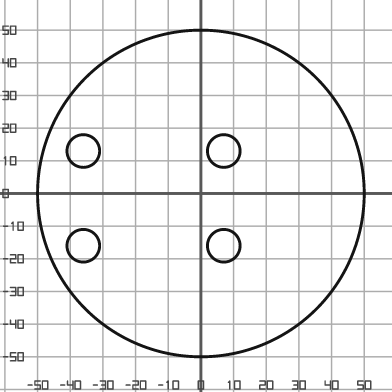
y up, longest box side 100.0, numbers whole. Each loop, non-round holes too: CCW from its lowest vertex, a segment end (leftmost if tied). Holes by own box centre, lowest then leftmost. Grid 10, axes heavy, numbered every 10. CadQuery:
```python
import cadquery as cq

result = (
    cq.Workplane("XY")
    .moveTo(0.0, 0.0)
    .circle(50.0)
    .moveTo(-36.0, -16.0)
    .circle(5.0)
    .moveTo(7.0, -16.0)
    .circle(5.0)
    .moveTo(-36.0, 13.0)
    .circle(5.0)
    .moveTo(7.0, 13.0)
    .circle(5.0)
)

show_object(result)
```